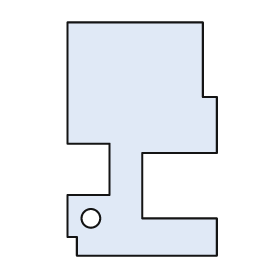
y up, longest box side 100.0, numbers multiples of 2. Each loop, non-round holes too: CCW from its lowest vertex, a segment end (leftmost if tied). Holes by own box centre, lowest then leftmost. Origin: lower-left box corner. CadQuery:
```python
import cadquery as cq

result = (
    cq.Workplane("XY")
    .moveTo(4.0, 0.0)
    .lineTo(64.0, 0.0)
    .lineTo(64.0, 16.0)
    .lineTo(32.0, 16.0)
    .lineTo(32.0, 44.0)
    .lineTo(64.0, 44.0)
    .lineTo(64.0, 68.0)
    .lineTo(58.0, 68.0)
    .lineTo(58.0, 100.0)
    .lineTo(0.0, 100.0)
    .lineTo(0.0, 48.0)
    .lineTo(18.0, 48.0)
    .lineTo(18.0, 26.0)
    .lineTo(0.0, 26.0)
    .lineTo(0.0, 8.0)
    .lineTo(4.0, 8.0)
    .close()
    .moveTo(10.0, 16.0)
    .circle(4.0)
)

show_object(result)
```